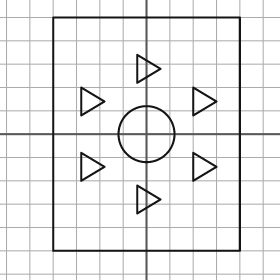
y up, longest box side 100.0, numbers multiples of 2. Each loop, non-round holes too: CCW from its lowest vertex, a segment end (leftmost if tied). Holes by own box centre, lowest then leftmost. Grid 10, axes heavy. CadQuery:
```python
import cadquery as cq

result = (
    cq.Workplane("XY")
    .moveTo(-40.0, -50.0)
    .lineTo(40.0, -50.0)
    .lineTo(40.0, 50.0)
    .lineTo(-40.0, 50.0)
    .close()
    .moveTo(-4.0, -34.0)
    .lineTo(6.0, -28.0)
    .lineTo(-4.0, -22.0)
    .close()
    .moveTo(-28.0, -20.0)
    .lineTo(-18.0, -14.0)
    .lineTo(-28.0, -8.0)
    .close()
    .moveTo(20.0, -20.0)
    .lineTo(30.0, -14.0)
    .lineTo(20.0, -8.0)
    .close()
    .moveTo(0.0, 0.0)
    .circle(12.0)
    .moveTo(-28.0, 8.0)
    .lineTo(-18.0, 14.0)
    .lineTo(-28.0, 20.0)
    .close()
    .moveTo(20.0, 8.0)
    .lineTo(30.0, 14.0)
    .lineTo(20.0, 20.0)
    .close()
    .moveTo(-4.0, 22.0)
    .lineTo(6.0, 28.0)
    .lineTo(-4.0, 34.0)
    .close()
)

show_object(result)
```